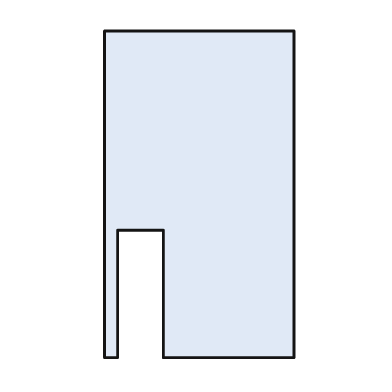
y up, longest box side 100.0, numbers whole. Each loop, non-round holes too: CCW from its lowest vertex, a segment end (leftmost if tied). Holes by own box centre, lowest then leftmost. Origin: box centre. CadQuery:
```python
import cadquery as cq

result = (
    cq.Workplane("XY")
    .moveTo(-29.0, -50.0)
    .lineTo(-25.0, -50.0)
    .lineTo(-25.0, -11.0)
    .lineTo(-11.0, -11.0)
    .lineTo(-11.0, -50.0)
    .lineTo(29.0, -50.0)
    .lineTo(29.0, 50.0)
    .lineTo(-29.0, 50.0)
    .close()
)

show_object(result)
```